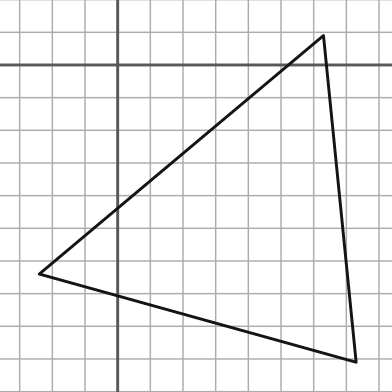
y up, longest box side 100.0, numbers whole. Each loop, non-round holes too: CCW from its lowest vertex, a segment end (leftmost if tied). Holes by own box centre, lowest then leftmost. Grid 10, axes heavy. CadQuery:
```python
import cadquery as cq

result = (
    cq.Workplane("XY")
    .moveTo(73.0, -91.0)
    .lineTo(63.0, 9.0)
    .lineTo(-24.0, -64.0)
    .close()
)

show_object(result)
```